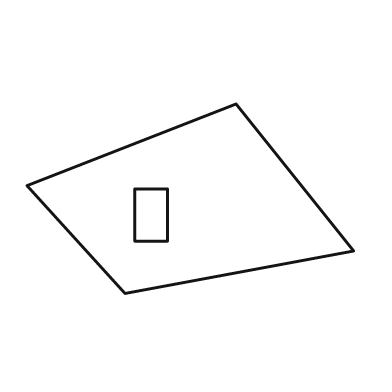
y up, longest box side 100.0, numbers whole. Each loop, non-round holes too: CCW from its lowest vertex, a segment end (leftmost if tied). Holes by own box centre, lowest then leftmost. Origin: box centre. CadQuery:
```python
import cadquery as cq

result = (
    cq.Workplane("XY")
    .moveTo(-20.0, -29.0)
    .lineTo(50.0, -16.0)
    .lineTo(14.0, 29.0)
    .lineTo(-50.0, 4.0)
    .close()
    .moveTo(-17.0, -13.0)
    .lineTo(-7.0, -13.0)
    .lineTo(-7.0, 3.0)
    .lineTo(-17.0, 3.0)
    .close()
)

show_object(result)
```